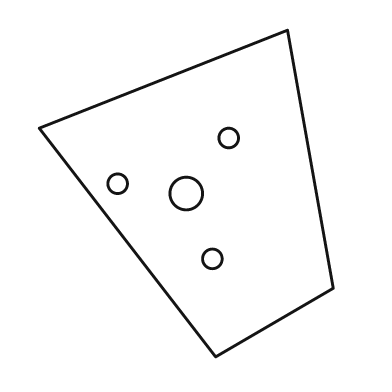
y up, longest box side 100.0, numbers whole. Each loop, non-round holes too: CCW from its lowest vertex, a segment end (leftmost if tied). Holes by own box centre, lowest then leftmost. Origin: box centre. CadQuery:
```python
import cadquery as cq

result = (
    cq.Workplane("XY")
    .moveTo(9.0, -50.0)
    .lineTo(45.0, -29.0)
    .lineTo(31.0, 50.0)
    .lineTo(-45.0, 20.0)
    .close()
    .moveTo(8.0, -20.0)
    .circle(3.0)
    .moveTo(0.0, 0.0)
    .circle(5.0)
    .moveTo(-21.0, 3.0)
    .circle(3.0)
    .moveTo(13.0, 17.0)
    .circle(3.0)
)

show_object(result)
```